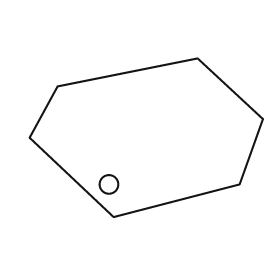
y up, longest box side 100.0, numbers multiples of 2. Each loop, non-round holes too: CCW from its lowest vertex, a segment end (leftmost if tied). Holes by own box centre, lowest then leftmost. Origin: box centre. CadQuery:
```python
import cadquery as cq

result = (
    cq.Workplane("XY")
    .moveTo(-14.0, -34.0)
    .lineTo(40.0, -20.0)
    .lineTo(50.0, 8.0)
    .lineTo(22.0, 34.0)
    .lineTo(-38.0, 22.0)
    .lineTo(-50.0, 0.0)
    .close()
    .moveTo(-16.0, -20.0)
    .circle(4.0)
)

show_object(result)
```